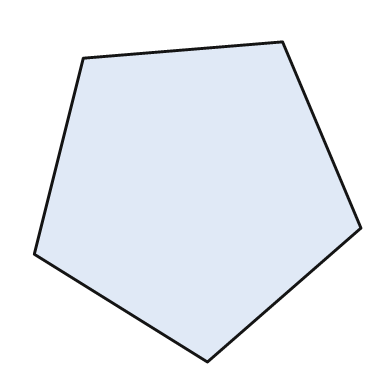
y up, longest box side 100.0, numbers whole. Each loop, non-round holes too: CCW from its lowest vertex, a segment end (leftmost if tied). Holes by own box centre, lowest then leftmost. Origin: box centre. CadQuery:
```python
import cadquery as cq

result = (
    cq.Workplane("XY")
    .moveTo(3.0, -49.0)
    .lineTo(50.0, -8.0)
    .lineTo(26.0, 49.0)
    .lineTo(-35.0, 44.0)
    .lineTo(-50.0, -16.0)
    .close()
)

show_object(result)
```